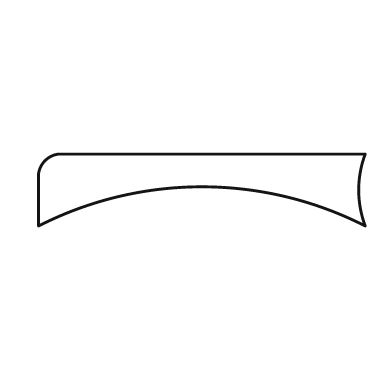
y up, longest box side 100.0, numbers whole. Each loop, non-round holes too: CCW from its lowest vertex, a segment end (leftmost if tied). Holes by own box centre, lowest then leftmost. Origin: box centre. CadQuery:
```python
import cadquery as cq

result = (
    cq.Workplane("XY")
    .moveTo(-50.0, -11.0)
    .threePointArc((0.0, 1.0), (50.0, -11.0))
    .threePointArc((48.0, 0.0), (50.0, 11.0))
    .lineTo(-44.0, 11.0)
    .threePointArc((-48.0, 9.0), (-50.0, 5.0))
    .close()
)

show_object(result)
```